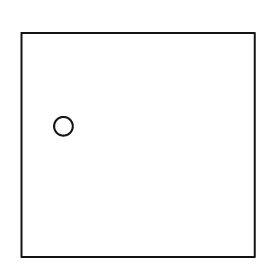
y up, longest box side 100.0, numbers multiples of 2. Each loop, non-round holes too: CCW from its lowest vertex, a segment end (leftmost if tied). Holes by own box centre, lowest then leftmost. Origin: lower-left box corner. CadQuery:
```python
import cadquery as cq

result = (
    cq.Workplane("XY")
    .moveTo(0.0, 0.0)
    .lineTo(100.0, 0.0)
    .lineTo(100.0, 96.0)
    .lineTo(0.0, 96.0)
    .close()
    .moveTo(18.0, 56.0)
    .circle(4.0)
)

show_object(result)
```